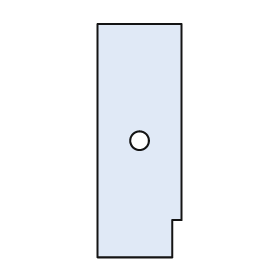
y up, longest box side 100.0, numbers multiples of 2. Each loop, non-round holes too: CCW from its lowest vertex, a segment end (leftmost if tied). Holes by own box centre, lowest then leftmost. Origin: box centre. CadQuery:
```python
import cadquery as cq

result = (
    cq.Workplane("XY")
    .moveTo(-18.0, -50.0)
    .lineTo(14.0, -50.0)
    .lineTo(14.0, -34.0)
    .lineTo(18.0, -34.0)
    .lineTo(18.0, 50.0)
    .lineTo(-18.0, 50.0)
    .close()
    .moveTo(0.0, 0.0)
    .circle(4.0)
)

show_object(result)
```